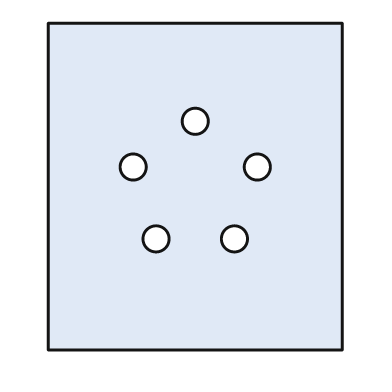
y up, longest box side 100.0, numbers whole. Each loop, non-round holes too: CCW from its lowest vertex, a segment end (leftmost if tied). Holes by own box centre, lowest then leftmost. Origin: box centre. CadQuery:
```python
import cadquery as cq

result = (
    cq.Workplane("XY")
    .moveTo(-45.0, -50.0)
    .lineTo(45.0, -50.0)
    .lineTo(45.0, 50.0)
    .lineTo(-45.0, 50.0)
    .close()
    .moveTo(-12.0, -16.0)
    .circle(4.0)
    .moveTo(12.0, -16.0)
    .circle(4.0)
    .moveTo(-19.0, 6.0)
    .circle(4.0)
    .moveTo(19.0, 6.0)
    .circle(4.0)
    .moveTo(0.0, 20.0)
    .circle(4.0)
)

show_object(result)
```